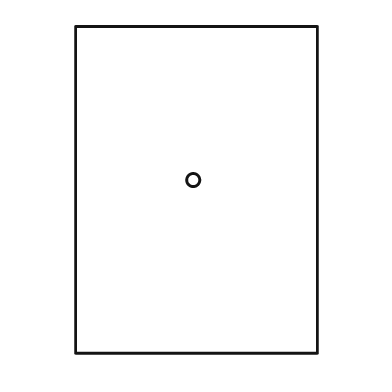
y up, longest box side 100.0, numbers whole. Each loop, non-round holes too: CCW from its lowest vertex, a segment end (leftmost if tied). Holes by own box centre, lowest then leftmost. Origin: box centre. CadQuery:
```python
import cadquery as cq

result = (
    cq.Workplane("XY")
    .moveTo(-37.0, -50.0)
    .lineTo(37.0, -50.0)
    .lineTo(37.0, 50.0)
    .lineTo(-37.0, 50.0)
    .close()
    .moveTo(-1.0, 3.0)
    .circle(2.0)
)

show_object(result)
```